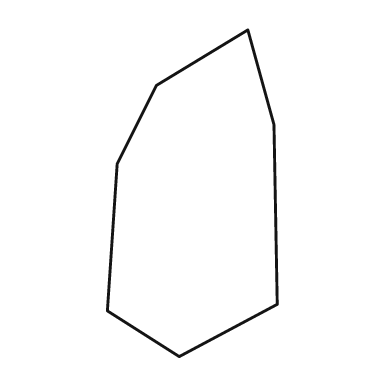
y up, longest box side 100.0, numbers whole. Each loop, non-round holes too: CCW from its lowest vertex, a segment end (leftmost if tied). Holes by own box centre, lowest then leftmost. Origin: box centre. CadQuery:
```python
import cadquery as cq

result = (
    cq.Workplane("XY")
    .moveTo(-4.0, -50.0)
    .lineTo(26.0, -34.0)
    .lineTo(25.0, 21.0)
    .lineTo(17.0, 50.0)
    .lineTo(-11.0, 33.0)
    .lineTo(-23.0, 9.0)
    .lineTo(-26.0, -36.0)
    .close()
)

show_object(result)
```